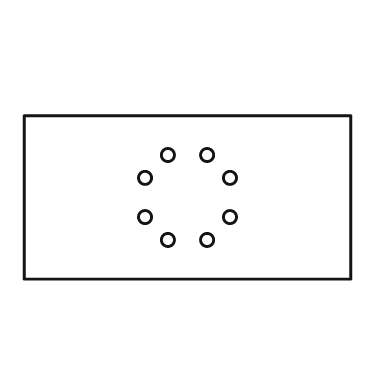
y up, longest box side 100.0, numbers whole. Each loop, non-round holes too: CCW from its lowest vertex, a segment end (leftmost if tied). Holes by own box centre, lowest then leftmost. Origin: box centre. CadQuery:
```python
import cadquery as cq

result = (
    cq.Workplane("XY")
    .moveTo(-50.0, -25.0)
    .lineTo(50.0, -25.0)
    .lineTo(50.0, 25.0)
    .lineTo(-50.0, 25.0)
    .close()
    .moveTo(-6.0, -13.0)
    .circle(2.0)
    .moveTo(6.0, -13.0)
    .circle(2.0)
    .moveTo(-13.0, -6.0)
    .circle(2.0)
    .moveTo(13.0, -6.0)
    .circle(2.0)
    .moveTo(-13.0, 6.0)
    .circle(2.0)
    .moveTo(13.0, 6.0)
    .circle(2.0)
    .moveTo(-6.0, 13.0)
    .circle(2.0)
    .moveTo(6.0, 13.0)
    .circle(2.0)
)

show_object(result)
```